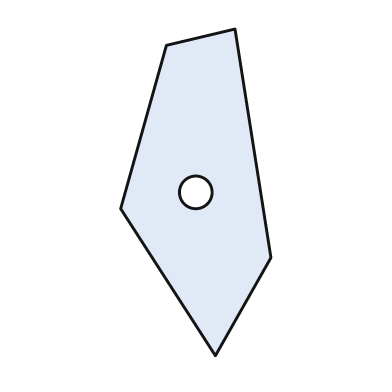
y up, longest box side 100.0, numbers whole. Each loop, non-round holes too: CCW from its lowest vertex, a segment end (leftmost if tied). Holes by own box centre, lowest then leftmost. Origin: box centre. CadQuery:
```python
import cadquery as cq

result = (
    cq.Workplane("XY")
    .moveTo(6.0, -50.0)
    .lineTo(23.0, -20.0)
    .lineTo(12.0, 50.0)
    .lineTo(-9.0, 45.0)
    .lineTo(-23.0, -5.0)
    .close()
    .moveTo(0.0, 0.0)
    .circle(5.0)
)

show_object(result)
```